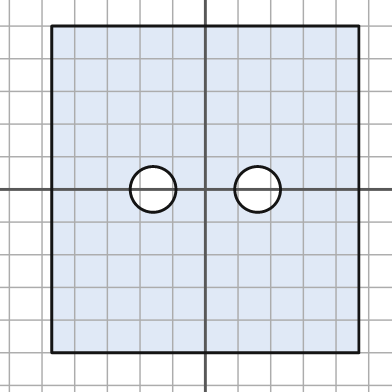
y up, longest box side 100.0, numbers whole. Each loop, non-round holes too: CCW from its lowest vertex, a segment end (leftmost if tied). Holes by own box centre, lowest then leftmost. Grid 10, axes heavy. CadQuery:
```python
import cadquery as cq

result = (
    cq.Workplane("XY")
    .moveTo(-47.0, -50.0)
    .lineTo(47.0, -50.0)
    .lineTo(47.0, 50.0)
    .lineTo(-47.0, 50.0)
    .close()
    .moveTo(-16.0, 0.0)
    .circle(7.0)
    .moveTo(16.0, 0.0)
    .circle(7.0)
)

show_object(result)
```